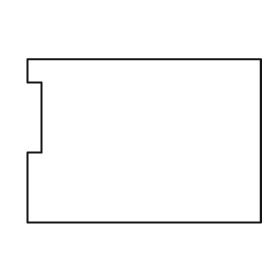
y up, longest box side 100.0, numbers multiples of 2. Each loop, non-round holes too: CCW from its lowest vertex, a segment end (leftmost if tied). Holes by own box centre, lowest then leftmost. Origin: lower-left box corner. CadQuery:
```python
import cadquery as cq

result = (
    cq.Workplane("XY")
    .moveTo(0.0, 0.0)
    .lineTo(100.0, 0.0)
    .lineTo(100.0, 70.0)
    .lineTo(0.0, 70.0)
    .lineTo(0.0, 60.0)
    .lineTo(6.0, 60.0)
    .lineTo(6.0, 30.0)
    .lineTo(0.0, 30.0)
    .close()
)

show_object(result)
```